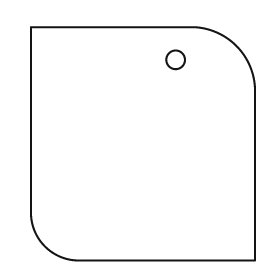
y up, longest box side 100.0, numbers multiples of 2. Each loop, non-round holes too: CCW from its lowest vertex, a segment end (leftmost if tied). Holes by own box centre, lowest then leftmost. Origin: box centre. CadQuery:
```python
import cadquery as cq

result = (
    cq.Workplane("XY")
    .moveTo(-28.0, -50.0)
    .lineTo(48.0, -50.0)
    .lineTo(48.0, 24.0)
    .threePointArc((40.0, 42.0), (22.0, 50.0))
    .lineTo(-48.0, 50.0)
    .lineTo(-48.0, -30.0)
    .threePointArc((-42.0, -44.0), (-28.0, -50.0))
    .close()
    .moveTo(14.0, 36.0)
    .circle(4.0)
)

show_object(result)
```